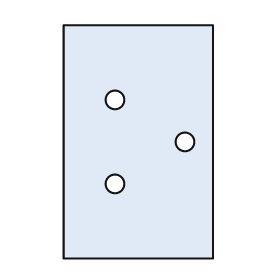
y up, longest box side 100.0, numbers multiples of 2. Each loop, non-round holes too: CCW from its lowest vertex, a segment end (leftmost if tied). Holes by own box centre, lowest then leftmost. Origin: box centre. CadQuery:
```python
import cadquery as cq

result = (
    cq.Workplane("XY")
    .moveTo(-32.0, -50.0)
    .lineTo(32.0, -50.0)
    .lineTo(32.0, 50.0)
    .lineTo(-32.0, 50.0)
    .close()
    .moveTo(-10.0, -18.0)
    .circle(4.0)
    .moveTo(20.0, 0.0)
    .circle(4.0)
    .moveTo(-10.0, 18.0)
    .circle(4.0)
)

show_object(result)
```